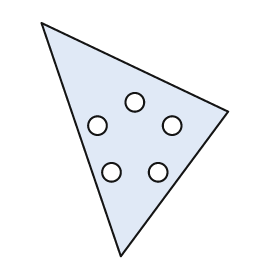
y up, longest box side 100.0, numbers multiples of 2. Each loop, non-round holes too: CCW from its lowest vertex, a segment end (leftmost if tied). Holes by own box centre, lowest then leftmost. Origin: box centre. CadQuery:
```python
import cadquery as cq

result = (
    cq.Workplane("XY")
    .moveTo(-6.0, -50.0)
    .lineTo(40.0, 12.0)
    .lineTo(-40.0, 50.0)
    .close()
    .moveTo(-10.0, -14.0)
    .circle(4.0)
    .moveTo(10.0, -14.0)
    .circle(4.0)
    .moveTo(-16.0, 6.0)
    .circle(4.0)
    .moveTo(16.0, 6.0)
    .circle(4.0)
    .moveTo(0.0, 16.0)
    .circle(4.0)
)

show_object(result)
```